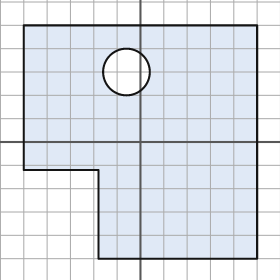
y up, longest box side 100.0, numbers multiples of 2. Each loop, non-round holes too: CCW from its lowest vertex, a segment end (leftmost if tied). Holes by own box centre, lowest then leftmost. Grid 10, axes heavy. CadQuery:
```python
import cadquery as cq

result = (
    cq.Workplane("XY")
    .moveTo(-18.0, -50.0)
    .lineTo(50.0, -50.0)
    .lineTo(50.0, 50.0)
    .lineTo(-50.0, 50.0)
    .lineTo(-50.0, -12.0)
    .lineTo(-18.0, -12.0)
    .close()
    .moveTo(-6.0, 30.0)
    .circle(10.0)
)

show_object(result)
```